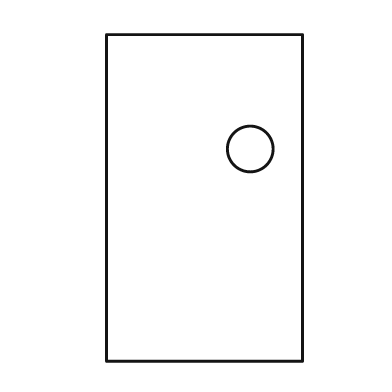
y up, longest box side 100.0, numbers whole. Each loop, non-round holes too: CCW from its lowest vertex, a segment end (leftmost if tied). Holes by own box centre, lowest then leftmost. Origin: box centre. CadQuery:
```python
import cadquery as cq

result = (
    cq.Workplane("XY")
    .moveTo(-30.0, -50.0)
    .lineTo(30.0, -50.0)
    .lineTo(30.0, 50.0)
    .lineTo(-30.0, 50.0)
    .close()
    .moveTo(14.0, 15.0)
    .circle(7.0)
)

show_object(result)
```